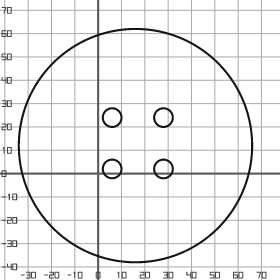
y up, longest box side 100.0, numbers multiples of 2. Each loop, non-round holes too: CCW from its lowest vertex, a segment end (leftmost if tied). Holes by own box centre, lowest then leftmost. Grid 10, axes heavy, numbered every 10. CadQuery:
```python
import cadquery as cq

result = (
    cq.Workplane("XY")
    .moveTo(16.0, 12.0)
    .circle(50.0)
    .moveTo(6.0, 2.0)
    .circle(4.0)
    .moveTo(28.0, 2.0)
    .circle(4.0)
    .moveTo(6.0, 24.0)
    .circle(4.0)
    .moveTo(28.0, 24.0)
    .circle(4.0)
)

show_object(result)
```